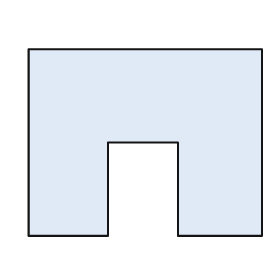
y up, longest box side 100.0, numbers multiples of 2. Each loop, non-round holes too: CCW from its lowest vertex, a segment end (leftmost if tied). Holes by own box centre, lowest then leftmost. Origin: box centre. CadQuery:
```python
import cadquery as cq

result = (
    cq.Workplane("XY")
    .moveTo(-50.0, -40.0)
    .lineTo(-16.0, -40.0)
    .lineTo(-16.0, 0.0)
    .lineTo(14.0, 0.0)
    .lineTo(14.0, -40.0)
    .lineTo(50.0, -40.0)
    .lineTo(50.0, 40.0)
    .lineTo(-50.0, 40.0)
    .close()
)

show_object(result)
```